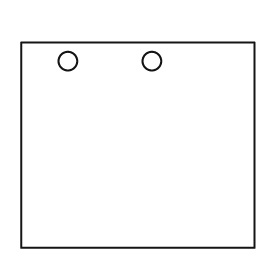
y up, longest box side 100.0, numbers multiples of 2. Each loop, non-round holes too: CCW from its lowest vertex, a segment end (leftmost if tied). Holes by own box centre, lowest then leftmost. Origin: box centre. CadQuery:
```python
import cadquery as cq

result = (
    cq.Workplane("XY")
    .moveTo(-50.0, -44.0)
    .lineTo(50.0, -44.0)
    .lineTo(50.0, 44.0)
    .lineTo(-50.0, 44.0)
    .close()
    .moveTo(-30.0, 36.0)
    .circle(4.0)
    .moveTo(6.0, 36.0)
    .circle(4.0)
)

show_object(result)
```